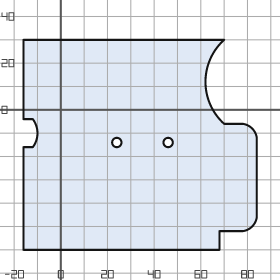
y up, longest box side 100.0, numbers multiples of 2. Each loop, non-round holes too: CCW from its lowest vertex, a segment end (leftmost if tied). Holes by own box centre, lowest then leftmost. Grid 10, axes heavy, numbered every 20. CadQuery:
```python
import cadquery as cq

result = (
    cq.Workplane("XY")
    .moveTo(-16.0, -60.0)
    .lineTo(68.0, -60.0)
    .lineTo(68.0, -52.0)
    .lineTo(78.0, -52.0)
    .threePointArc((82.0, -50.0), (84.0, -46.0))
    .lineTo(84.0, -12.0)
    .threePointArc((82.0, -8.0), (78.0, -6.0))
    .lineTo(70.0, -6.0)
    .threePointArc((62.0, 12.0), (70.0, 30.0))
    .lineTo(-16.0, 30.0)
    .lineTo(-16.0, -4.0)
    .lineTo(-12.0, -4.0)
    .threePointArc((-10.0, -10.0), (-12.0, -16.0))
    .lineTo(-16.0, -16.0)
    .close()
    .moveTo(24.0, -14.0)
    .circle(2.0)
    .moveTo(46.0, -14.0)
    .circle(2.0)
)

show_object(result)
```